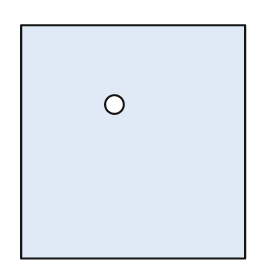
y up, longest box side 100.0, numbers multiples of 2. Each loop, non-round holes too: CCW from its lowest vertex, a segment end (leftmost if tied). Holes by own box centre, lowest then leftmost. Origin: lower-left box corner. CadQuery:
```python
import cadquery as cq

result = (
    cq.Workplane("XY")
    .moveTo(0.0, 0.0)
    .lineTo(96.0, 0.0)
    .lineTo(96.0, 100.0)
    .lineTo(0.0, 100.0)
    .close()
    .moveTo(40.0, 66.0)
    .circle(4.0)
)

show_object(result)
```